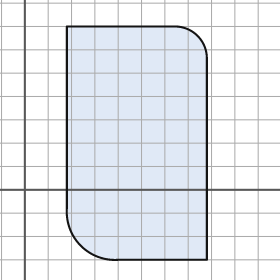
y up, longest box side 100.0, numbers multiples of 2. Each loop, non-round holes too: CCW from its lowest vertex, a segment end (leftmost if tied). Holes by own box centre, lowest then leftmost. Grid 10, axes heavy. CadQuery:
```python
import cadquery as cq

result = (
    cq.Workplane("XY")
    .moveTo(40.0, -30.0)
    .lineTo(78.0, -30.0)
    .lineTo(78.0, 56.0)
    .threePointArc((74.0, 66.0), (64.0, 70.0))
    .lineTo(18.0, 70.0)
    .lineTo(18.0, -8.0)
    .threePointArc((24.0, -24.0), (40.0, -30.0))
    .close()
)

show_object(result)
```